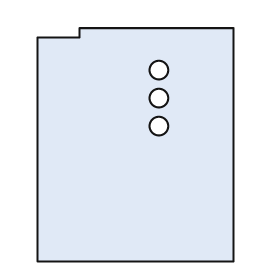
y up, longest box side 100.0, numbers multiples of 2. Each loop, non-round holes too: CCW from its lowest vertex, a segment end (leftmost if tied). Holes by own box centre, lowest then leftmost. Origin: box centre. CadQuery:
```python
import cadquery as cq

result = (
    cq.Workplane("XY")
    .moveTo(-42.0, -50.0)
    .lineTo(42.0, -50.0)
    .lineTo(42.0, 50.0)
    .lineTo(-24.0, 50.0)
    .lineTo(-24.0, 46.0)
    .lineTo(-42.0, 46.0)
    .close()
    .moveTo(10.0, 8.0)
    .circle(4.0)
    .moveTo(10.0, 20.0)
    .circle(4.0)
    .moveTo(10.0, 32.0)
    .circle(4.0)
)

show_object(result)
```